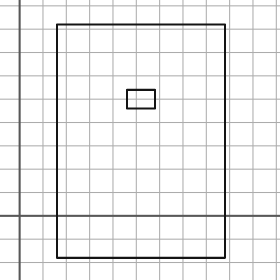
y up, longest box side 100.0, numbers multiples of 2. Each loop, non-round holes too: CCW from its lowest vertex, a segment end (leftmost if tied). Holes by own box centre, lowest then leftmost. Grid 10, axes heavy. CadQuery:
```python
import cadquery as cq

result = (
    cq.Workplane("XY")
    .moveTo(16.0, -18.0)
    .lineTo(88.0, -18.0)
    .lineTo(88.0, 82.0)
    .lineTo(16.0, 82.0)
    .close()
    .moveTo(46.0, 46.0)
    .lineTo(58.0, 46.0)
    .lineTo(58.0, 54.0)
    .lineTo(46.0, 54.0)
    .close()
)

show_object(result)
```